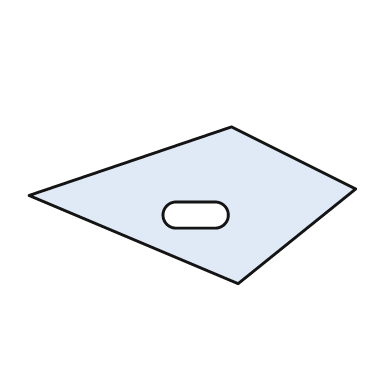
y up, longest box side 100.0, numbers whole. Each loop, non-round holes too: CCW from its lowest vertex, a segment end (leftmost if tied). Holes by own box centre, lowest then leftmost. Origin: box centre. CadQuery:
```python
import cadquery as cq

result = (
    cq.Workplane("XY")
    .moveTo(14.0, -24.0)
    .lineTo(50.0, 5.0)
    .lineTo(12.0, 24.0)
    .lineTo(-50.0, 3.0)
    .close()
    .moveTo(-5.0, -7.0)
    .lineTo(7.0, -7.0)
    .threePointArc((11.0, -3.0), (7.0, 1.0))
    .lineTo(-5.0, 1.0)
    .threePointArc((-9.0, -3.0), (-5.0, -7.0))
    .close()
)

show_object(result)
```